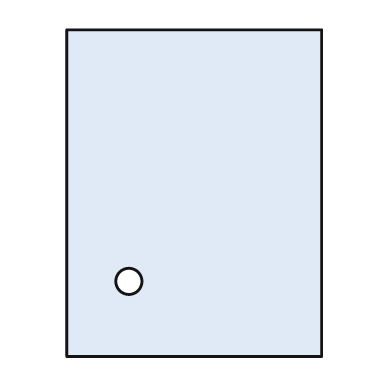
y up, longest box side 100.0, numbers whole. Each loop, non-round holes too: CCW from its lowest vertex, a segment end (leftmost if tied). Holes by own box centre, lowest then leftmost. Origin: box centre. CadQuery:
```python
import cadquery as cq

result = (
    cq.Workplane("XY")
    .moveTo(-39.0, -50.0)
    .lineTo(39.0, -50.0)
    .lineTo(39.0, 50.0)
    .lineTo(-39.0, 50.0)
    .close()
    .moveTo(-20.0, -27.0)
    .circle(4.0)
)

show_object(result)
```